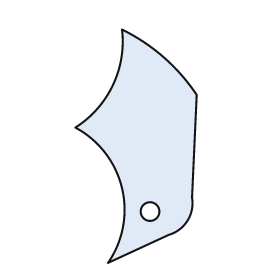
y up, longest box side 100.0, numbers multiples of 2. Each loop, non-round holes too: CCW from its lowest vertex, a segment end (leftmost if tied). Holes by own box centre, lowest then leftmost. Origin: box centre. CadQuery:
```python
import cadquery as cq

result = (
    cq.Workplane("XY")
    .moveTo(-12.0, -50.0)
    .lineTo(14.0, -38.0)
    .threePointArc((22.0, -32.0), (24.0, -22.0))
    .lineTo(26.0, 22.0)
    .threePointArc((12.0, 38.0), (-6.0, 50.0))
    .threePointArc((-10.0, 26.0), (-26.0, 8.0))
    .threePointArc((-6.0, -18.0), (-12.0, -50.0))
    .close()
    .moveTo(6.0, -28.0)
    .circle(4.0)
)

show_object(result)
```